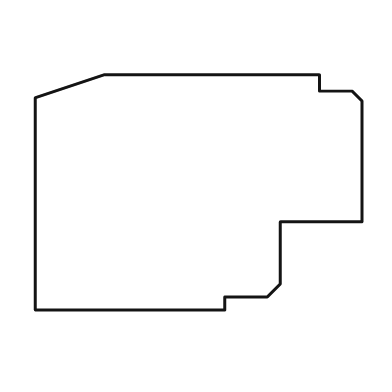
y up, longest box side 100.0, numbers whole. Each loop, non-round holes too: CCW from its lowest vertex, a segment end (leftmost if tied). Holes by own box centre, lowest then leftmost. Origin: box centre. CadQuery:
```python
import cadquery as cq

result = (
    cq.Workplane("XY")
    .moveTo(-50.0, -36.0)
    .lineTo(8.0, -36.0)
    .lineTo(8.0, -32.0)
    .lineTo(21.0, -32.0)
    .lineTo(25.0, -28.0)
    .lineTo(25.0, -9.0)
    .lineTo(50.0, -9.0)
    .lineTo(50.0, 28.0)
    .lineTo(47.0, 31.0)
    .lineTo(37.0, 31.0)
    .lineTo(37.0, 36.0)
    .lineTo(-29.0, 36.0)
    .lineTo(-50.0, 29.0)
    .close()
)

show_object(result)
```